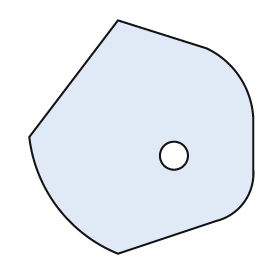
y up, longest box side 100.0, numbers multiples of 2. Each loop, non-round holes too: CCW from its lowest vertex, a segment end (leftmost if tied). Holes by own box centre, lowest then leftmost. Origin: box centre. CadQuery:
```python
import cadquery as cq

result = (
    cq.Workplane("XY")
    .moveTo(-10.0, -50.0)
    .lineTo(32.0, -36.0)
    .threePointArc((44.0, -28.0), (48.0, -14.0))
    .lineTo(48.0, 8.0)
    .threePointArc((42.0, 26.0), (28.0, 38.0))
    .lineTo(-10.0, 50.0)
    .lineTo(-48.0, 0.0)
    .threePointArc((-36.0, -30.0), (-10.0, -50.0))
    .close()
    .moveTo(14.0, -8.0)
    .circle(6.0)
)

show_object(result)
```